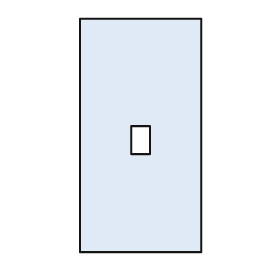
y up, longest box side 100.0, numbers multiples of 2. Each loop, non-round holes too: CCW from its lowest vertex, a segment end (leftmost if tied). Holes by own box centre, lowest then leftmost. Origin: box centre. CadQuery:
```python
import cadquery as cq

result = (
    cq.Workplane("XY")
    .moveTo(-26.0, -50.0)
    .lineTo(26.0, -50.0)
    .lineTo(26.0, 50.0)
    .lineTo(-26.0, 50.0)
    .close()
    .moveTo(-4.0, -8.0)
    .lineTo(4.0, -8.0)
    .lineTo(4.0, 4.0)
    .lineTo(-4.0, 4.0)
    .close()
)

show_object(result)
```